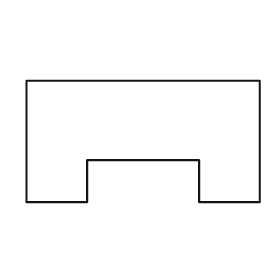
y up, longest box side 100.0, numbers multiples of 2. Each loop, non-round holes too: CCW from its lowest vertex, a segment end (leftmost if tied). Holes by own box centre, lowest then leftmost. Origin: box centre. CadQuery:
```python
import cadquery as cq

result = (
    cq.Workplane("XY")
    .moveTo(-50.0, -26.0)
    .lineTo(-24.0, -26.0)
    .lineTo(-24.0, -8.0)
    .lineTo(24.0, -8.0)
    .lineTo(24.0, -26.0)
    .lineTo(50.0, -26.0)
    .lineTo(50.0, 26.0)
    .lineTo(-50.0, 26.0)
    .close()
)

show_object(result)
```